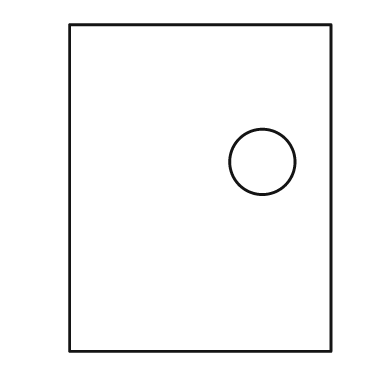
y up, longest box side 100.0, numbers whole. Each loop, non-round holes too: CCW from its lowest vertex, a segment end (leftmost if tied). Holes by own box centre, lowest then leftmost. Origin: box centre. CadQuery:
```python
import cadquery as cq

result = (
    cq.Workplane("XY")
    .moveTo(-40.0, -50.0)
    .lineTo(40.0, -50.0)
    .lineTo(40.0, 50.0)
    .lineTo(-40.0, 50.0)
    .close()
    .moveTo(19.0, 8.0)
    .circle(10.0)
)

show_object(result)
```